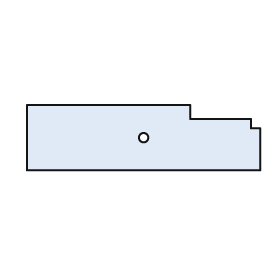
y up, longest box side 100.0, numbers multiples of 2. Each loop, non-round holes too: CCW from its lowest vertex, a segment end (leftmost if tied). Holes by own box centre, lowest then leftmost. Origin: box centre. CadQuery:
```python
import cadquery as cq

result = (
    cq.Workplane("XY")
    .moveTo(-50.0, -14.0)
    .lineTo(50.0, -14.0)
    .lineTo(50.0, 4.0)
    .lineTo(46.0, 4.0)
    .lineTo(46.0, 8.0)
    .lineTo(20.0, 8.0)
    .lineTo(20.0, 14.0)
    .lineTo(-50.0, 14.0)
    .close()
    .moveTo(0.0, 0.0)
    .circle(2.0)
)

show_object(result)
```